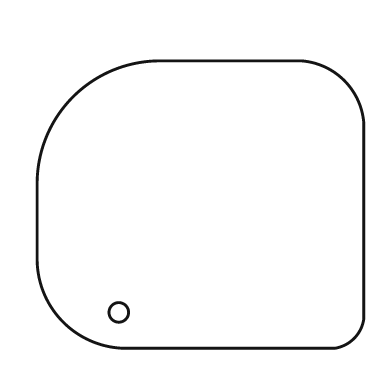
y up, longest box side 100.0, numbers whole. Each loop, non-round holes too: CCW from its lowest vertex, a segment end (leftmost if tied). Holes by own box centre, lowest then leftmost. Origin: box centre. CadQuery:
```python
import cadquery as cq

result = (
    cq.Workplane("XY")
    .moveTo(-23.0, -44.0)
    .lineTo(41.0, -44.0)
    .threePointArc((47.0, -41.0), (50.0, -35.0))
    .lineTo(50.0, 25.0)
    .threePointArc((44.0, 38.0), (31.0, 44.0))
    .lineTo(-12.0, 44.0)
    .threePointArc((-39.0, 33.0), (-50.0, 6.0))
    .lineTo(-50.0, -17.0)
    .threePointArc((-42.0, -36.0), (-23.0, -44.0))
    .close()
    .moveTo(-25.0, -33.0)
    .circle(3.0)
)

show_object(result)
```